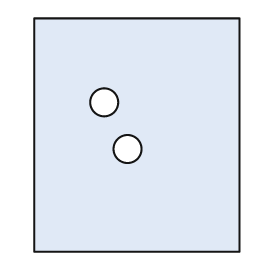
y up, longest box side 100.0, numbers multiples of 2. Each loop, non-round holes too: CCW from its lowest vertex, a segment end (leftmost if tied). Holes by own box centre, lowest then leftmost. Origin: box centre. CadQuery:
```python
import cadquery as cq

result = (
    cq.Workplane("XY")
    .moveTo(-44.0, -50.0)
    .lineTo(44.0, -50.0)
    .lineTo(44.0, 50.0)
    .lineTo(-44.0, 50.0)
    .close()
    .moveTo(-4.0, -6.0)
    .circle(6.0)
    .moveTo(-14.0, 14.0)
    .circle(6.0)
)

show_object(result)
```